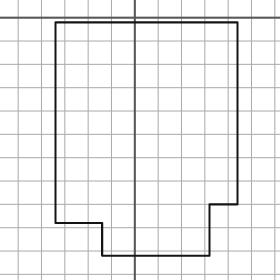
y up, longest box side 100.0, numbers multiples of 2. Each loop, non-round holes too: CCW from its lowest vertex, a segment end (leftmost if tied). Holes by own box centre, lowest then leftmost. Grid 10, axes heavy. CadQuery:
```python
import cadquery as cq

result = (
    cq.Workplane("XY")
    .moveTo(-14.0, -102.0)
    .lineTo(32.0, -102.0)
    .lineTo(32.0, -80.0)
    .lineTo(44.0, -80.0)
    .lineTo(44.0, -2.0)
    .lineTo(-34.0, -2.0)
    .lineTo(-34.0, -88.0)
    .lineTo(-14.0, -88.0)
    .close()
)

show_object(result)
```